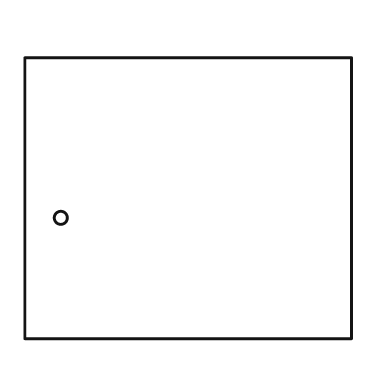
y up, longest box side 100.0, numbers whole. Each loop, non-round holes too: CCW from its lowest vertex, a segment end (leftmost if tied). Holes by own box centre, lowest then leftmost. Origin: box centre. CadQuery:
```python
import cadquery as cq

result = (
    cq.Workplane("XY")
    .moveTo(-50.0, -43.0)
    .lineTo(50.0, -43.0)
    .lineTo(50.0, 43.0)
    .lineTo(-50.0, 43.0)
    .close()
    .moveTo(-39.0, -6.0)
    .circle(2.0)
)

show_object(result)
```